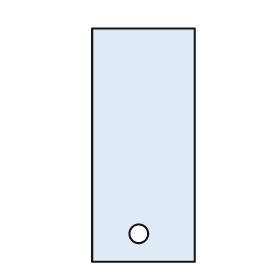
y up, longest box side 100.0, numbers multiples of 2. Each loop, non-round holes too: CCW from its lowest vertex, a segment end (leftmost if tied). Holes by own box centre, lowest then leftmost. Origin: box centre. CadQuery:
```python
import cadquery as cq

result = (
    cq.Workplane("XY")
    .moveTo(-22.0, -50.0)
    .lineTo(22.0, -50.0)
    .lineTo(22.0, 50.0)
    .lineTo(-22.0, 50.0)
    .close()
    .moveTo(-2.0, -38.0)
    .circle(4.0)
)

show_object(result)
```